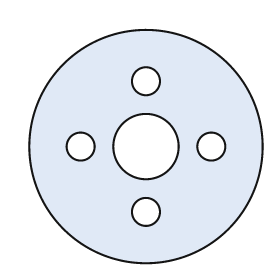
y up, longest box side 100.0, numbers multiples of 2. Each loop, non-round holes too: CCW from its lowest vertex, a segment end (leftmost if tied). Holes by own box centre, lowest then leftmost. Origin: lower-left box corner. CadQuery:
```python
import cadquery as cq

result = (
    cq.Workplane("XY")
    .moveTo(50.0, 50.0)
    .circle(50.0)
    .moveTo(50.0, 22.0)
    .circle(6.0)
    .moveTo(22.0, 50.0)
    .circle(6.0)
    .moveTo(50.0, 50.0)
    .circle(14.0)
    .moveTo(78.0, 50.0)
    .circle(6.0)
    .moveTo(50.0, 78.0)
    .circle(6.0)
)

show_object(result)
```